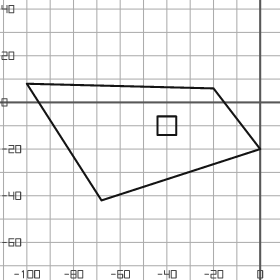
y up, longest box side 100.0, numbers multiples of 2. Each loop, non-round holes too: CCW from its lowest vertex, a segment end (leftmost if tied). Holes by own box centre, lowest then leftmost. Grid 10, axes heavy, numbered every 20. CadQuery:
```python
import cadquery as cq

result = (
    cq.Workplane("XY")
    .moveTo(-68.0, -42.0)
    .lineTo(0.0, -20.0)
    .lineTo(-20.0, 6.0)
    .lineTo(-100.0, 8.0)
    .close()
    .moveTo(-44.0, -14.0)
    .lineTo(-36.0, -14.0)
    .lineTo(-36.0, -6.0)
    .lineTo(-44.0, -6.0)
    .close()
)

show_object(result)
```